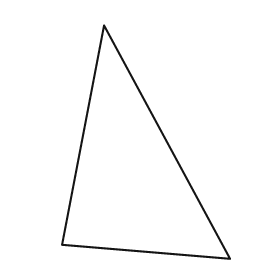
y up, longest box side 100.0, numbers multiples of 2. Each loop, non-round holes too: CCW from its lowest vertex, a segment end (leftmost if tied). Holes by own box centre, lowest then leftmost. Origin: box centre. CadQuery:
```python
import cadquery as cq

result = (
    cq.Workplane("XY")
    .moveTo(36.0, -50.0)
    .lineTo(-18.0, 50.0)
    .lineTo(-36.0, -44.0)
    .close()
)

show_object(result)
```